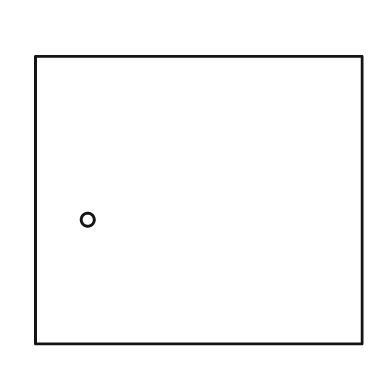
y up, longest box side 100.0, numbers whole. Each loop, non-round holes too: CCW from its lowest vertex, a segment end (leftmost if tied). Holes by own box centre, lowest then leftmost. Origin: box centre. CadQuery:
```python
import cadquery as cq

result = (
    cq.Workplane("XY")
    .moveTo(-50.0, -44.0)
    .lineTo(50.0, -44.0)
    .lineTo(50.0, 44.0)
    .lineTo(-50.0, 44.0)
    .close()
    .moveTo(-34.0, -6.0)
    .circle(2.0)
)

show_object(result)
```